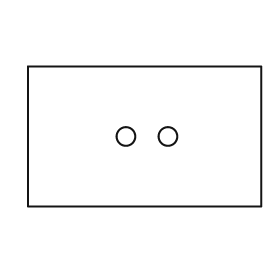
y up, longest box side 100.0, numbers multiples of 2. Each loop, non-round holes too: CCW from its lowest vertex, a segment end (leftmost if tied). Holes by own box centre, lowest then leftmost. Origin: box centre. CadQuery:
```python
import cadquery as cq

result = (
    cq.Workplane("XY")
    .moveTo(-50.0, -30.0)
    .lineTo(50.0, -30.0)
    .lineTo(50.0, 30.0)
    .lineTo(-50.0, 30.0)
    .close()
    .moveTo(-8.0, 0.0)
    .circle(4.0)
    .moveTo(10.0, 0.0)
    .circle(4.0)
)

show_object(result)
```